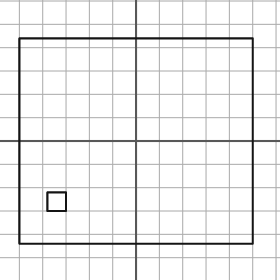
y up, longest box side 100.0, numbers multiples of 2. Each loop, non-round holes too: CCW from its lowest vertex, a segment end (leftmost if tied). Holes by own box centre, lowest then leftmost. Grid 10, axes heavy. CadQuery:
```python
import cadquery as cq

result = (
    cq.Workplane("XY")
    .moveTo(-50.0, -44.0)
    .lineTo(50.0, -44.0)
    .lineTo(50.0, 44.0)
    .lineTo(-50.0, 44.0)
    .close()
    .moveTo(-38.0, -30.0)
    .lineTo(-30.0, -30.0)
    .lineTo(-30.0, -22.0)
    .lineTo(-38.0, -22.0)
    .close()
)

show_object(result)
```